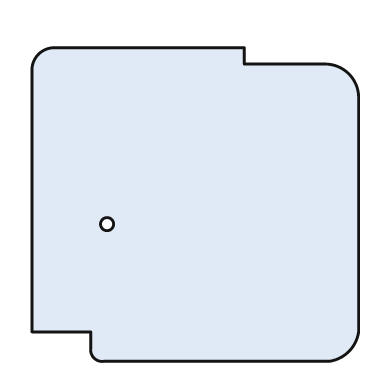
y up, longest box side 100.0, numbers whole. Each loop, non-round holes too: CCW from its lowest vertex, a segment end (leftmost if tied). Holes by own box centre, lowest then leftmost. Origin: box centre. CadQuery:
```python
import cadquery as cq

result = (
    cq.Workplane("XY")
    .moveTo(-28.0, -48.0)
    .lineTo(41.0, -48.0)
    .threePointArc((47.0, -45.0), (50.0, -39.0))
    .lineTo(50.0, 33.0)
    .threePointArc((47.0, 40.0), (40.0, 43.0))
    .lineTo(15.0, 43.0)
    .lineTo(15.0, 48.0)
    .lineTo(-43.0, 48.0)
    .threePointArc((-48.0, 46.0), (-50.0, 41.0))
    .lineTo(-50.0, -39.0)
    .lineTo(-32.0, -39.0)
    .lineTo(-32.0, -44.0)
    .threePointArc((-31.0, -47.0), (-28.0, -48.0))
    .close()
    .moveTo(-27.0, -6.0)
    .circle(2.0)
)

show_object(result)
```